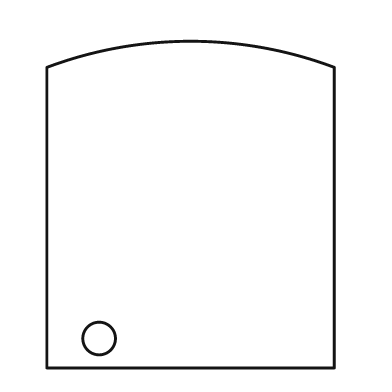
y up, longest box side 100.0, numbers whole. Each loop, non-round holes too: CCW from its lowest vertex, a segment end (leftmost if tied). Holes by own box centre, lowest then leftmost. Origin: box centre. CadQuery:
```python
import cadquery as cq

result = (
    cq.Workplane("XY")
    .moveTo(-44.0, -50.0)
    .lineTo(44.0, -50.0)
    .lineTo(44.0, 42.0)
    .threePointArc((0.0, 50.0), (-44.0, 42.0))
    .close()
    .moveTo(-28.0, -41.0)
    .circle(5.0)
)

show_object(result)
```